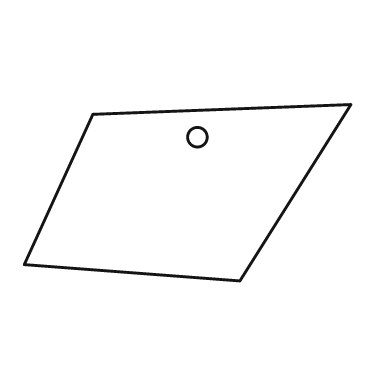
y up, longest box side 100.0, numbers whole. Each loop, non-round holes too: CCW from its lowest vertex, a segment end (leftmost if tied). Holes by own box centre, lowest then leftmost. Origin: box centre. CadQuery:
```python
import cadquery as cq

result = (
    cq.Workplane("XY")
    .moveTo(16.0, -27.0)
    .lineTo(50.0, 27.0)
    .lineTo(-29.0, 24.0)
    .lineTo(-50.0, -22.0)
    .close()
    .moveTo(3.0, 17.0)
    .circle(3.0)
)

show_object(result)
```